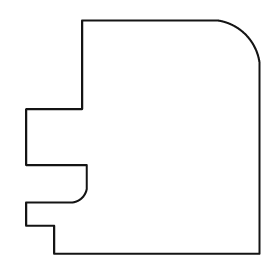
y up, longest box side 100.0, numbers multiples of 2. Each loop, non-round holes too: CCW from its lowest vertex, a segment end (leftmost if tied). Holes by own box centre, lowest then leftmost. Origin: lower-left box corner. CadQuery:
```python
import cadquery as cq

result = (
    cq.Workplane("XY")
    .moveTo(12.0, 0.0)
    .lineTo(100.0, 0.0)
    .lineTo(100.0, 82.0)
    .threePointArc((94.0, 94.0), (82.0, 100.0))
    .lineTo(24.0, 100.0)
    .lineTo(24.0, 62.0)
    .lineTo(0.0, 62.0)
    .lineTo(0.0, 38.0)
    .lineTo(26.0, 38.0)
    .lineTo(26.0, 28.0)
    .threePointArc((24.0, 24.0), (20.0, 22.0))
    .lineTo(0.0, 22.0)
    .lineTo(0.0, 12.0)
    .lineTo(12.0, 12.0)
    .close()
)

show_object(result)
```